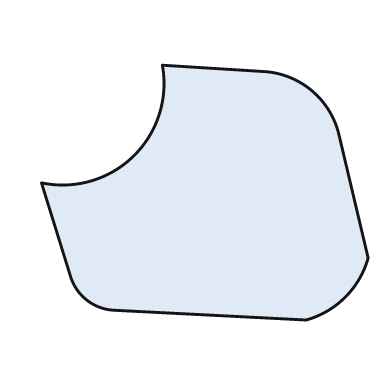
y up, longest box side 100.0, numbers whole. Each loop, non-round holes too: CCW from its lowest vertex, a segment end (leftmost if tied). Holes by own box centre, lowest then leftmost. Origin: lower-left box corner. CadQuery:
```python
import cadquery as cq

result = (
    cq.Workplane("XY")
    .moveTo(81.0, 0.0)
    .threePointArc((93.0, 7.0), (100.0, 19.0))
    .lineTo(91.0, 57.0)
    .threePointArc((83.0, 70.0), (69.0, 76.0))
    .lineTo(37.0, 78.0)
    .threePointArc((28.0, 50.0), (0.0, 42.0))
    .lineTo(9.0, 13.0)
    .threePointArc((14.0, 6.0), (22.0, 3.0))
    .close()
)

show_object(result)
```